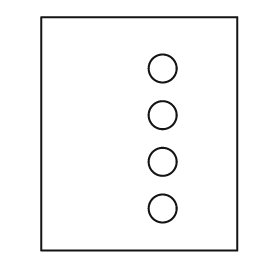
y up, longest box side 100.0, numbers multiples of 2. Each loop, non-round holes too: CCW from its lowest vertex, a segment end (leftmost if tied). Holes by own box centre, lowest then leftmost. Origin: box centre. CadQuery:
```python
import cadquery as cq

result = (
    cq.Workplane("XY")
    .moveTo(-42.0, -50.0)
    .lineTo(42.0, -50.0)
    .lineTo(42.0, 50.0)
    .lineTo(-42.0, 50.0)
    .close()
    .moveTo(10.0, -32.0)
    .circle(6.0)
    .moveTo(10.0, -12.0)
    .circle(6.0)
    .moveTo(10.0, 8.0)
    .circle(6.0)
    .moveTo(10.0, 28.0)
    .circle(6.0)
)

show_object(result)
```